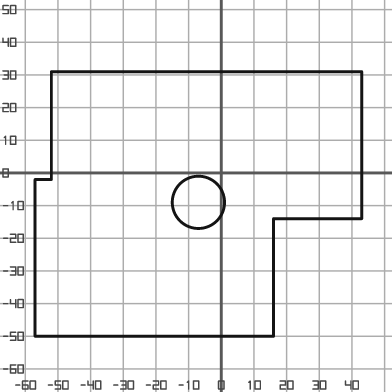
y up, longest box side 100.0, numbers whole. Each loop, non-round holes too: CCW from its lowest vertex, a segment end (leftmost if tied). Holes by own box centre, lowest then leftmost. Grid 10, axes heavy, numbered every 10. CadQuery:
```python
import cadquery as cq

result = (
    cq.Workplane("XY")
    .moveTo(-57.0, -50.0)
    .lineTo(16.0, -50.0)
    .lineTo(16.0, -14.0)
    .lineTo(43.0, -14.0)
    .lineTo(43.0, 31.0)
    .lineTo(-52.0, 31.0)
    .lineTo(-52.0, -2.0)
    .lineTo(-57.0, -2.0)
    .close()
    .moveTo(-7.0, -9.0)
    .circle(8.0)
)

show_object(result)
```